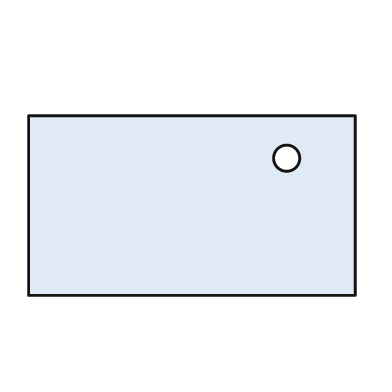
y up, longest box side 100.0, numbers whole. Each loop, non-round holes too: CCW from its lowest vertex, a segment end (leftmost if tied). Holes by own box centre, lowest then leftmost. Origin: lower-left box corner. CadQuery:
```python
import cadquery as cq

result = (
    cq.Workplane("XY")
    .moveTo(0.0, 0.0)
    .lineTo(100.0, 0.0)
    .lineTo(100.0, 55.0)
    .lineTo(0.0, 55.0)
    .close()
    .moveTo(79.0, 42.0)
    .circle(4.0)
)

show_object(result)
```